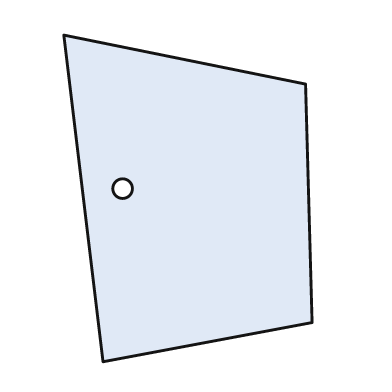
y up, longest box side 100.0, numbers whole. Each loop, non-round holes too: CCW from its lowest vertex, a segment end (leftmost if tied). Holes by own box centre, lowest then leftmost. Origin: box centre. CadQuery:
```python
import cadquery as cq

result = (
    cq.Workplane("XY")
    .moveTo(-26.0, -50.0)
    .lineTo(38.0, -38.0)
    .lineTo(36.0, 35.0)
    .lineTo(-38.0, 50.0)
    .close()
    .moveTo(-20.0, 3.0)
    .circle(3.0)
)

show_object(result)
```